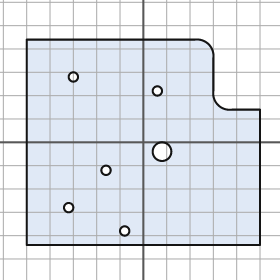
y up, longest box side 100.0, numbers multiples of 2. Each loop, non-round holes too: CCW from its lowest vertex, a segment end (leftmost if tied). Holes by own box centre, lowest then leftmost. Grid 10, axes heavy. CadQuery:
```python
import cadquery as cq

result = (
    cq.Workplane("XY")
    .moveTo(-50.0, -44.0)
    .lineTo(50.0, -44.0)
    .lineTo(50.0, 14.0)
    .lineTo(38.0, 14.0)
    .threePointArc((32.0, 16.0), (30.0, 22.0))
    .lineTo(30.0, 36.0)
    .threePointArc((28.0, 42.0), (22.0, 44.0))
    .lineTo(-50.0, 44.0)
    .close()
    .moveTo(-8.0, -38.0)
    .circle(2.0)
    .moveTo(-32.0, -28.0)
    .circle(2.0)
    .moveTo(-16.0, -12.0)
    .circle(2.0)
    .moveTo(8.0, -4.0)
    .circle(4.0)
    .moveTo(6.0, 22.0)
    .circle(2.0)
    .moveTo(-30.0, 28.0)
    .circle(2.0)
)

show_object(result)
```